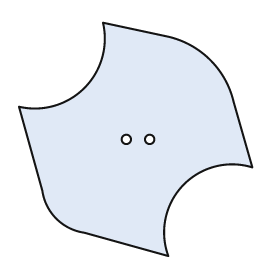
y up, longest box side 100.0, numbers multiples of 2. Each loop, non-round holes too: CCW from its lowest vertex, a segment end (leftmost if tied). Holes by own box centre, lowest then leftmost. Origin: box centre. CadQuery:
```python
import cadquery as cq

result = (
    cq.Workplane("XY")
    .moveTo(14.0, -50.0)
    .threePointArc((20.0, -20.0), (50.0, -12.0))
    .lineTo(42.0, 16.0)
    .threePointArc((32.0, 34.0), (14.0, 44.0))
    .lineTo(-14.0, 50.0)
    .threePointArc((-22.0, 22.0), (-50.0, 14.0))
    .lineTo(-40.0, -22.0)
    .threePointArc((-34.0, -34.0), (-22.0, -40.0))
    .close()
    .moveTo(-4.0, 0.0)
    .circle(2.0)
    .moveTo(6.0, 0.0)
    .circle(2.0)
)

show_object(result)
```